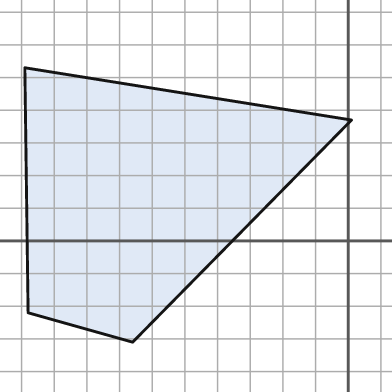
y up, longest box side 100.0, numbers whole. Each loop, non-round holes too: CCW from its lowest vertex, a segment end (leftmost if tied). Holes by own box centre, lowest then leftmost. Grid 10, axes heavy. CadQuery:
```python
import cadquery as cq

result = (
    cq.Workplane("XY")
    .moveTo(-66.0, -31.0)
    .lineTo(1.0, 37.0)
    .lineTo(-99.0, 53.0)
    .lineTo(-98.0, -22.0)
    .close()
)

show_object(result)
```